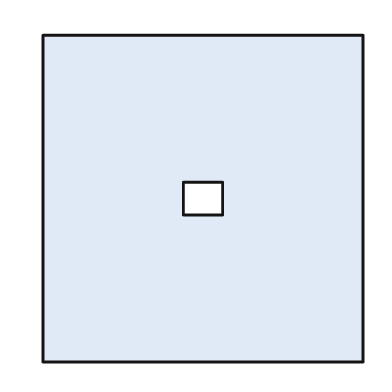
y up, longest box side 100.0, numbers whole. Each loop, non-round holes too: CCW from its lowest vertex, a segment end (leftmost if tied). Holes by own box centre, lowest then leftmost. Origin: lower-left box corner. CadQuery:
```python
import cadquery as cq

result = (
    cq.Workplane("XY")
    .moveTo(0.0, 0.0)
    .lineTo(98.0, 0.0)
    .lineTo(98.0, 100.0)
    .lineTo(0.0, 100.0)
    .close()
    .moveTo(43.0, 45.0)
    .lineTo(55.0, 45.0)
    .lineTo(55.0, 55.0)
    .lineTo(43.0, 55.0)
    .close()
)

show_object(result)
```